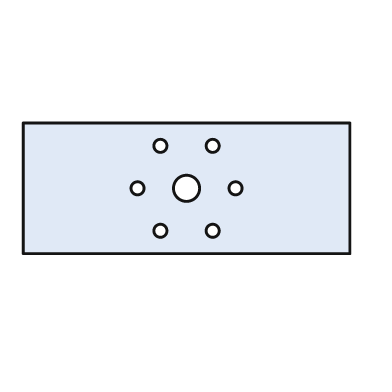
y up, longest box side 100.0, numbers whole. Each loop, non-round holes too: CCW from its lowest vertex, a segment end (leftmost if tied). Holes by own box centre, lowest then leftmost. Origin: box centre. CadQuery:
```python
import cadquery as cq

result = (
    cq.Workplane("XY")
    .moveTo(-50.0, -20.0)
    .lineTo(50.0, -20.0)
    .lineTo(50.0, 20.0)
    .lineTo(-50.0, 20.0)
    .close()
    .moveTo(-8.0, -13.0)
    .circle(2.0)
    .moveTo(8.0, -13.0)
    .circle(2.0)
    .moveTo(-15.0, 0.0)
    .circle(2.0)
    .moveTo(0.0, 0.0)
    .circle(4.0)
    .moveTo(15.0, 0.0)
    .circle(2.0)
    .moveTo(-8.0, 13.0)
    .circle(2.0)
    .moveTo(8.0, 13.0)
    .circle(2.0)
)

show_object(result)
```